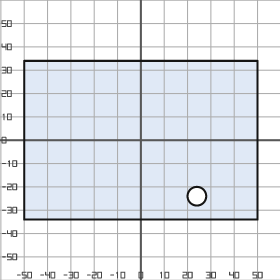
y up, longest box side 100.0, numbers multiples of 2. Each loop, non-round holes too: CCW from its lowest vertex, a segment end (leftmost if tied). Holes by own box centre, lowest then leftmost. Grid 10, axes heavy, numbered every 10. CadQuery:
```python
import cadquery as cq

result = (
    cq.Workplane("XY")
    .moveTo(-50.0, -34.0)
    .lineTo(50.0, -34.0)
    .lineTo(50.0, 34.0)
    .lineTo(-50.0, 34.0)
    .close()
    .moveTo(24.0, -24.0)
    .circle(4.0)
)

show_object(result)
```